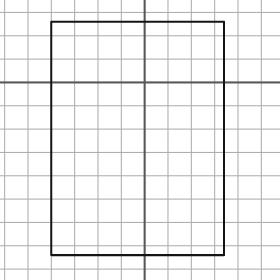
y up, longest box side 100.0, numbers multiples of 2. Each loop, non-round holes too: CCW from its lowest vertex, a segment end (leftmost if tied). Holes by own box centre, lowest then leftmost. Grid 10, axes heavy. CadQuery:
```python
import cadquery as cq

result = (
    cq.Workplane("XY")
    .moveTo(-40.0, -74.0)
    .lineTo(34.0, -74.0)
    .lineTo(34.0, 26.0)
    .lineTo(-40.0, 26.0)
    .close()
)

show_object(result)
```